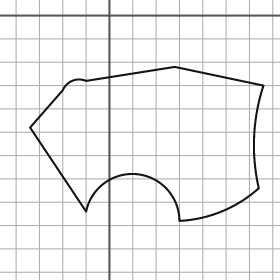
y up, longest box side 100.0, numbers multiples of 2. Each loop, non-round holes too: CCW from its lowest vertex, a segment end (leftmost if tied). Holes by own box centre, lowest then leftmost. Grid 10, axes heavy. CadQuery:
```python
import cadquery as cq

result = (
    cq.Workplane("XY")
    .moveTo(30.0, -88.0)
    .threePointArc((48.0, -84.0), (64.0, -74.0))
    .threePointArc((62.0, -52.0), (66.0, -30.0))
    .lineTo(28.0, -22.0)
    .lineTo(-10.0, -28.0)
    .threePointArc((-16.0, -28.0), (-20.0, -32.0))
    .lineTo(-34.0, -48.0)
    .lineTo(-10.0, -84.0)
    .threePointArc((12.0, -68.0), (30.0, -88.0))
    .close()
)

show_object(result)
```